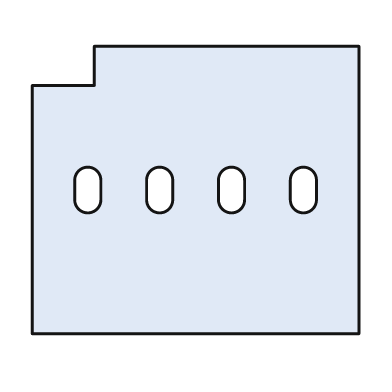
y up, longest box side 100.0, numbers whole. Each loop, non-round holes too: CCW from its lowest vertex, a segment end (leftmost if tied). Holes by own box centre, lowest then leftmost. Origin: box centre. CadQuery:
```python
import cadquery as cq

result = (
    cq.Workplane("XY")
    .moveTo(-50.0, -44.0)
    .lineTo(50.0, -44.0)
    .lineTo(50.0, 44.0)
    .lineTo(-31.0, 44.0)
    .lineTo(-31.0, 32.0)
    .lineTo(-50.0, 32.0)
    .close()
    .moveTo(-37.0, -3.0)
    .threePointArc((-33.0, -7.0), (-29.0, -3.0))
    .lineTo(-29.0, 3.0)
    .threePointArc((-33.0, 7.0), (-37.0, 3.0))
    .close()
    .moveTo(-15.0, -3.0)
    .threePointArc((-11.0, -7.0), (-7.0, -3.0))
    .lineTo(-7.0, 3.0)
    .threePointArc((-11.0, 7.0), (-15.0, 3.0))
    .close()
    .moveTo(7.0, -3.0)
    .threePointArc((11.0, -7.0), (15.0, -3.0))
    .lineTo(15.0, 3.0)
    .threePointArc((11.0, 7.0), (7.0, 3.0))
    .close()
    .moveTo(29.0, -3.0)
    .threePointArc((33.0, -7.0), (37.0, -3.0))
    .lineTo(37.0, 3.0)
    .threePointArc((33.0, 7.0), (29.0, 3.0))
    .close()
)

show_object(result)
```